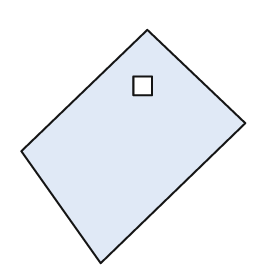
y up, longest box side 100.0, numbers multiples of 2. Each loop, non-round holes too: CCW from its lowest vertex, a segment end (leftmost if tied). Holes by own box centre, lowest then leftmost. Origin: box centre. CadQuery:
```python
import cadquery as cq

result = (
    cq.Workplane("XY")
    .moveTo(-14.0, -50.0)
    .lineTo(48.0, 10.0)
    .lineTo(6.0, 50.0)
    .lineTo(-48.0, -2.0)
    .close()
    .moveTo(0.0, 22.0)
    .lineTo(8.0, 22.0)
    .lineTo(8.0, 30.0)
    .lineTo(0.0, 30.0)
    .close()
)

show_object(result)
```